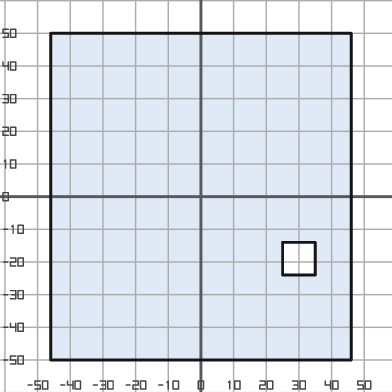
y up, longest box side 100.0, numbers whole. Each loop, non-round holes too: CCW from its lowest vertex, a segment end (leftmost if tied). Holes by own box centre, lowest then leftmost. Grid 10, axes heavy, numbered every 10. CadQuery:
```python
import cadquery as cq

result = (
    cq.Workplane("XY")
    .moveTo(-46.0, -50.0)
    .lineTo(46.0, -50.0)
    .lineTo(46.0, 50.0)
    .lineTo(-46.0, 50.0)
    .close()
    .moveTo(25.0, -24.0)
    .lineTo(35.0, -24.0)
    .lineTo(35.0, -14.0)
    .lineTo(25.0, -14.0)
    .close()
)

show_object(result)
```